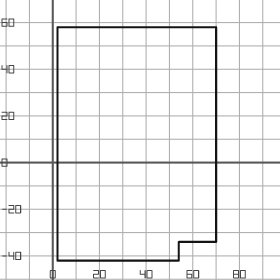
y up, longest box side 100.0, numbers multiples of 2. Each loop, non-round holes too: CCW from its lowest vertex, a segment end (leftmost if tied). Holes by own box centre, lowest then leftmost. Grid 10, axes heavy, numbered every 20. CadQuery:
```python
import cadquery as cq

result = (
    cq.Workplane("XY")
    .moveTo(2.0, -42.0)
    .lineTo(54.0, -42.0)
    .lineTo(54.0, -34.0)
    .lineTo(70.0, -34.0)
    .lineTo(70.0, 58.0)
    .lineTo(2.0, 58.0)
    .close()
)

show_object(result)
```